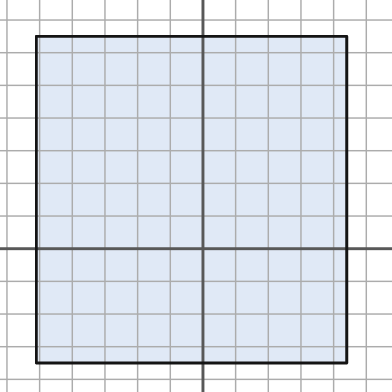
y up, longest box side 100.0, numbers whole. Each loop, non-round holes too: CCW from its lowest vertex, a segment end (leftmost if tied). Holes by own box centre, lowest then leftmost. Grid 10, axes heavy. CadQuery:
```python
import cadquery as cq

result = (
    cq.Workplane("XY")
    .moveTo(-51.0, -35.0)
    .lineTo(44.0, -35.0)
    .lineTo(44.0, 65.0)
    .lineTo(-51.0, 65.0)
    .close()
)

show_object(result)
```